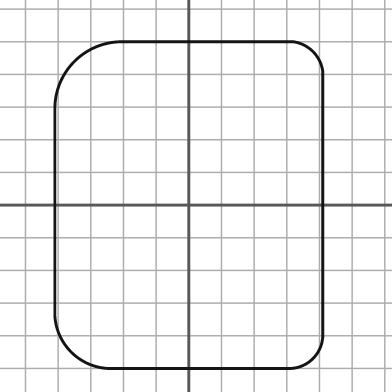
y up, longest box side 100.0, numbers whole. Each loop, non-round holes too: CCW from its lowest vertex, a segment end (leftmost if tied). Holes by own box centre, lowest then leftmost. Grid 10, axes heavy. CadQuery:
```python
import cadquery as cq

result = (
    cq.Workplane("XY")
    .moveTo(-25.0, -50.0)
    .lineTo(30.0, -50.0)
    .threePointArc((38.0, -47.0), (41.0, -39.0))
    .lineTo(41.0, 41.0)
    .threePointArc((38.0, 47.0), (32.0, 50.0))
    .lineTo(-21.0, 50.0)
    .threePointArc((-35.0, 44.0), (-41.0, 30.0))
    .lineTo(-41.0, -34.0)
    .threePointArc((-36.0, -45.0), (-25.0, -50.0))
    .close()
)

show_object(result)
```